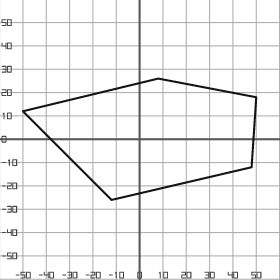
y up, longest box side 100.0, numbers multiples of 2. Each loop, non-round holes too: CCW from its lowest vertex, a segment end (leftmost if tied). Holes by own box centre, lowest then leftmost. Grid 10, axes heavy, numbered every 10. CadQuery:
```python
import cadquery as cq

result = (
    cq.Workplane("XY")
    .moveTo(-12.0, -26.0)
    .lineTo(48.0, -12.0)
    .lineTo(50.0, 18.0)
    .lineTo(8.0, 26.0)
    .lineTo(-50.0, 12.0)
    .close()
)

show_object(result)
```